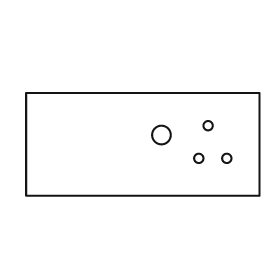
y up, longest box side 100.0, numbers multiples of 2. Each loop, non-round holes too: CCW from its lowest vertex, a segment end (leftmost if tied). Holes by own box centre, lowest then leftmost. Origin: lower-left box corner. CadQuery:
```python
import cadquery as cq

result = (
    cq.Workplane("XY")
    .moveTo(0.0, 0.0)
    .lineTo(100.0, 0.0)
    .lineTo(100.0, 44.0)
    .lineTo(0.0, 44.0)
    .close()
    .moveTo(74.0, 16.0)
    .circle(2.0)
    .moveTo(86.0, 16.0)
    .circle(2.0)
    .moveTo(58.0, 26.0)
    .circle(4.0)
    .moveTo(78.0, 30.0)
    .circle(2.0)
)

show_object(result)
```